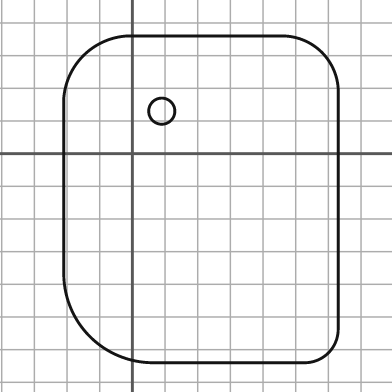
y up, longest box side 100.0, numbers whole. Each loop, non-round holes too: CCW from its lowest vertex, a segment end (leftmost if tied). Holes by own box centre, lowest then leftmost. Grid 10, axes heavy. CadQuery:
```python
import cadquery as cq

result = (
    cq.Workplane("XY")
    .moveTo(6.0, -64.0)
    .lineTo(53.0, -64.0)
    .threePointArc((60.0, -61.0), (63.0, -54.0))
    .lineTo(63.0, 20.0)
    .threePointArc((58.0, 31.0), (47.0, 36.0))
    .lineTo(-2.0, 36.0)
    .threePointArc((-15.0, 30.0), (-21.0, 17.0))
    .lineTo(-21.0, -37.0)
    .threePointArc((-13.0, -56.0), (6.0, -64.0))
    .close()
    .moveTo(9.0, 13.0)
    .circle(4.0)
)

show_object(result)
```